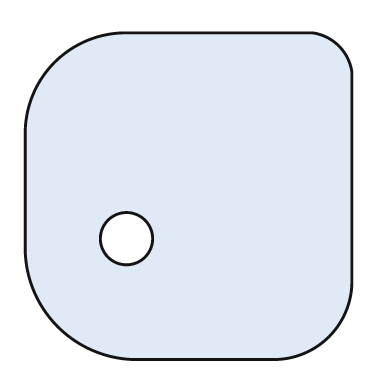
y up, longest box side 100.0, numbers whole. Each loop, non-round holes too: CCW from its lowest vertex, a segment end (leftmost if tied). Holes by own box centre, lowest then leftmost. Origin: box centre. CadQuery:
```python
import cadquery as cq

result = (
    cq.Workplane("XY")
    .moveTo(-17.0, -50.0)
    .lineTo(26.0, -50.0)
    .threePointArc((43.0, -43.0), (50.0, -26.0))
    .lineTo(50.0, 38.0)
    .threePointArc((46.0, 46.0), (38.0, 50.0))
    .lineTo(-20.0, 50.0)
    .threePointArc((-41.0, 41.0), (-50.0, 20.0))
    .lineTo(-50.0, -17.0)
    .threePointArc((-40.0, -40.0), (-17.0, -50.0))
    .close()
    .moveTo(-19.0, -13.0)
    .circle(8.0)
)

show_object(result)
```